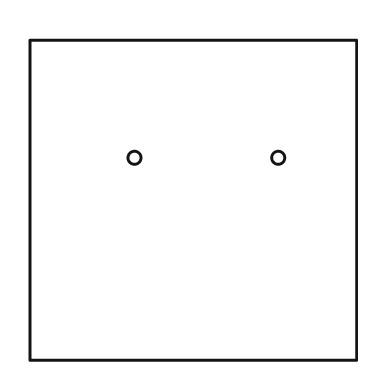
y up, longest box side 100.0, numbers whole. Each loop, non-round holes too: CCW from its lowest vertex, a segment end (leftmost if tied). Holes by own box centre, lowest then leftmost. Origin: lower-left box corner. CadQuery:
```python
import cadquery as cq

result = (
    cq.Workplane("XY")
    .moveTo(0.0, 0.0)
    .lineTo(100.0, 0.0)
    .lineTo(100.0, 98.0)
    .lineTo(0.0, 98.0)
    .close()
    .moveTo(32.0, 62.0)
    .circle(2.0)
    .moveTo(76.0, 62.0)
    .circle(2.0)
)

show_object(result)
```